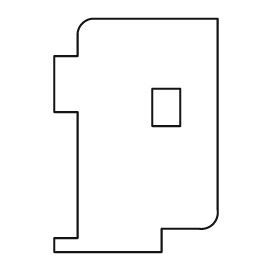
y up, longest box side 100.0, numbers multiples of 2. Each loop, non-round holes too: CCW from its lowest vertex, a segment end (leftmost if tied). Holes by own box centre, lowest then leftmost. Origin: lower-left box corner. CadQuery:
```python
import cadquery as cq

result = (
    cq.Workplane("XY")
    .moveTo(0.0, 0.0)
    .lineTo(46.0, 0.0)
    .lineTo(46.0, 10.0)
    .lineTo(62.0, 10.0)
    .threePointArc((68.0, 12.0), (70.0, 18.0))
    .lineTo(70.0, 100.0)
    .lineTo(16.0, 100.0)
    .threePointArc((12.0, 98.0), (10.0, 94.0))
    .lineTo(10.0, 84.0)
    .lineTo(0.0, 84.0)
    .lineTo(0.0, 60.0)
    .lineTo(10.0, 60.0)
    .lineTo(10.0, 6.0)
    .lineTo(0.0, 6.0)
    .close()
    .moveTo(42.0, 54.0)
    .lineTo(54.0, 54.0)
    .lineTo(54.0, 70.0)
    .lineTo(42.0, 70.0)
    .close()
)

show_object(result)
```